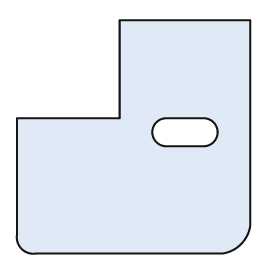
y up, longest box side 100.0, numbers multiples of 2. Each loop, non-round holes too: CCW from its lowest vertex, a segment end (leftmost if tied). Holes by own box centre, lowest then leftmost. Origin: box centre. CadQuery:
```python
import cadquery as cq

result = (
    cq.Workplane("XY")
    .moveTo(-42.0, -50.0)
    .lineTo(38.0, -50.0)
    .threePointArc((46.0, -46.0), (50.0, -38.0))
    .lineTo(50.0, 50.0)
    .lineTo(-6.0, 50.0)
    .lineTo(-6.0, 8.0)
    .lineTo(-50.0, 8.0)
    .lineTo(-50.0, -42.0)
    .threePointArc((-48.0, -48.0), (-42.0, -50.0))
    .close()
    .moveTo(14.0, -4.0)
    .lineTo(30.0, -4.0)
    .threePointArc((36.0, 2.0), (30.0, 8.0))
    .lineTo(14.0, 8.0)
    .threePointArc((8.0, 2.0), (14.0, -4.0))
    .close()
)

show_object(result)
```